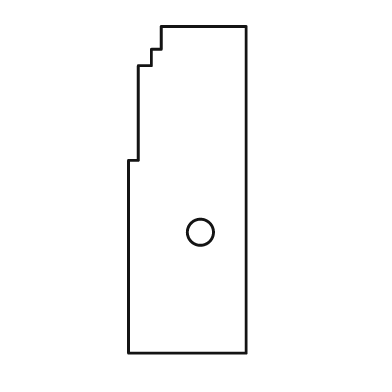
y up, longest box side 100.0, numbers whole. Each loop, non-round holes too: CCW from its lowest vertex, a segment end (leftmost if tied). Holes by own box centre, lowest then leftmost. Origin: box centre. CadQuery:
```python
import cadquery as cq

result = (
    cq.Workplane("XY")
    .moveTo(-18.0, -50.0)
    .lineTo(18.0, -50.0)
    .lineTo(18.0, 50.0)
    .lineTo(-8.0, 50.0)
    .lineTo(-8.0, 43.0)
    .lineTo(-11.0, 43.0)
    .lineTo(-11.0, 38.0)
    .lineTo(-15.0, 38.0)
    .lineTo(-15.0, 9.0)
    .lineTo(-18.0, 9.0)
    .close()
    .moveTo(4.0, -13.0)
    .circle(4.0)
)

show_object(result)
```